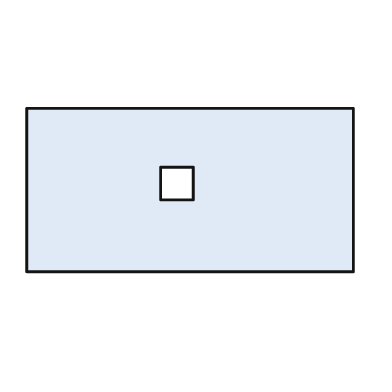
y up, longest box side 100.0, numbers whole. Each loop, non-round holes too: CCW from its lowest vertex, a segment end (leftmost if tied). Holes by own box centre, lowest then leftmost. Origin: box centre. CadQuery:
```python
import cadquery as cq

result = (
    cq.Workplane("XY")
    .moveTo(-50.0, -25.0)
    .lineTo(50.0, -25.0)
    .lineTo(50.0, 25.0)
    .lineTo(-50.0, 25.0)
    .close()
    .moveTo(-9.0, -3.0)
    .lineTo(1.0, -3.0)
    .lineTo(1.0, 7.0)
    .lineTo(-9.0, 7.0)
    .close()
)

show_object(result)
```